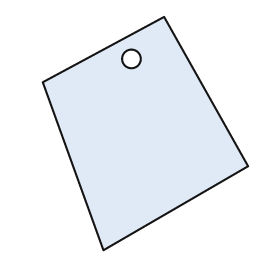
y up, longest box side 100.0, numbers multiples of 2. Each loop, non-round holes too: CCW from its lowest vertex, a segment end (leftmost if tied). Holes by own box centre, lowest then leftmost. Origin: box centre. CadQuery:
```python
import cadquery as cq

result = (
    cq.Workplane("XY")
    .moveTo(-18.0, -50.0)
    .lineTo(44.0, -14.0)
    .lineTo(8.0, 50.0)
    .lineTo(-44.0, 22.0)
    .close()
    .moveTo(-6.0, 32.0)
    .circle(4.0)
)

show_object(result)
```